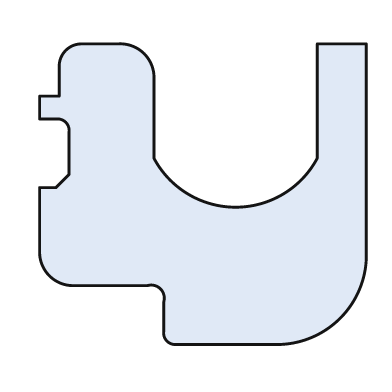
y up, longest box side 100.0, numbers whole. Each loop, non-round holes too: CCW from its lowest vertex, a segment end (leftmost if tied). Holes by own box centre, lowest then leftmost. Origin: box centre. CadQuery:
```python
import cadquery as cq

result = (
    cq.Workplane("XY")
    .moveTo(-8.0, -46.0)
    .lineTo(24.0, -46.0)
    .threePointArc((42.0, -38.0), (50.0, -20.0))
    .lineTo(50.0, 46.0)
    .lineTo(35.0, 46.0)
    .lineTo(35.0, 11.0)
    .threePointArc((10.0, -4.0), (-15.0, 11.0))
    .lineTo(-15.0, 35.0)
    .threePointArc((-18.0, 43.0), (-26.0, 46.0))
    .lineTo(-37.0, 46.0)
    .threePointArc((-42.0, 44.0), (-44.0, 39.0))
    .lineTo(-44.0, 30.0)
    .lineTo(-50.0, 30.0)
    .lineTo(-50.0, 23.0)
    .lineTo(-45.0, 23.0)
    .threePointArc((-42.0, 22.0), (-41.0, 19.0))
    .lineTo(-41.0, 6.0)
    .lineTo(-45.0, 2.0)
    .lineTo(-50.0, 2.0)
    .lineTo(-50.0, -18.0)
    .threePointArc((-47.0, -25.0), (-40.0, -28.0))
    .lineTo(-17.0, -28.0)
    .threePointArc((-13.0, -29.0), (-12.0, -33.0))
    .lineTo(-12.0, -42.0)
    .threePointArc((-11.0, -45.0), (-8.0, -46.0))
    .close()
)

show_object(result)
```